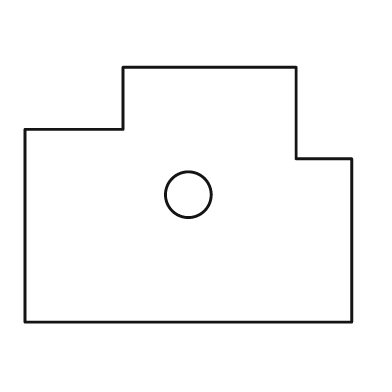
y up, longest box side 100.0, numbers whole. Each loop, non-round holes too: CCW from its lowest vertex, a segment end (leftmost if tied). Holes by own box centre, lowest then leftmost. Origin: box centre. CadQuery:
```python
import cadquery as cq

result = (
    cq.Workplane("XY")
    .moveTo(-50.0, -39.0)
    .lineTo(50.0, -39.0)
    .lineTo(50.0, 11.0)
    .lineTo(33.0, 11.0)
    .lineTo(33.0, 39.0)
    .lineTo(-20.0, 39.0)
    .lineTo(-20.0, 20.0)
    .lineTo(-50.0, 20.0)
    .close()
    .moveTo(0.0, 0.0)
    .circle(7.0)
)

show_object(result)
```